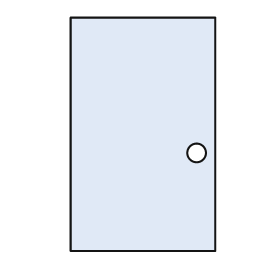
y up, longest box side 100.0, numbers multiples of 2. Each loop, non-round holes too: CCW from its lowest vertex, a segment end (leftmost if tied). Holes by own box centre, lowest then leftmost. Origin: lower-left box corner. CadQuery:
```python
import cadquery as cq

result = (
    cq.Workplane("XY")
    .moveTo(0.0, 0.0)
    .lineTo(62.0, 0.0)
    .lineTo(62.0, 100.0)
    .lineTo(0.0, 100.0)
    .close()
    .moveTo(54.0, 42.0)
    .circle(4.0)
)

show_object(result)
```